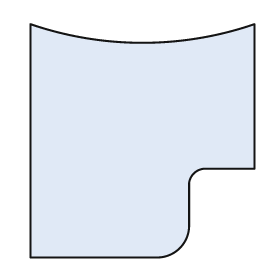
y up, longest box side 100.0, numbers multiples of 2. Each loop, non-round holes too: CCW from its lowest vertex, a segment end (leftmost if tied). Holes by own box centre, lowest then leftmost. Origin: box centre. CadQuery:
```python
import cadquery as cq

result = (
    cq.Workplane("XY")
    .moveTo(-48.0, -50.0)
    .lineTo(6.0, -50.0)
    .threePointArc((16.0, -46.0), (20.0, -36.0))
    .lineTo(20.0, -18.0)
    .threePointArc((22.0, -14.0), (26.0, -12.0))
    .lineTo(48.0, -12.0)
    .lineTo(48.0, 50.0)
    .threePointArc((0.0, 42.0), (-48.0, 50.0))
    .close()
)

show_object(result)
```